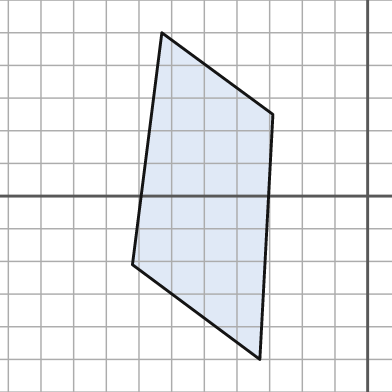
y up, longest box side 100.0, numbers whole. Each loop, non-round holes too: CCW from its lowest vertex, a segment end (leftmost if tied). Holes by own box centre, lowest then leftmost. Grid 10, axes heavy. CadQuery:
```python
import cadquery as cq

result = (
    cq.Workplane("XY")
    .moveTo(-33.0, -50.0)
    .lineTo(-29.0, 25.0)
    .lineTo(-63.0, 50.0)
    .lineTo(-72.0, -21.0)
    .close()
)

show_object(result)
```